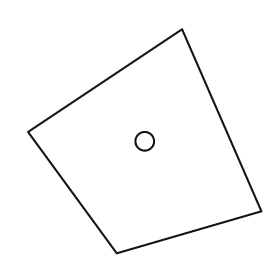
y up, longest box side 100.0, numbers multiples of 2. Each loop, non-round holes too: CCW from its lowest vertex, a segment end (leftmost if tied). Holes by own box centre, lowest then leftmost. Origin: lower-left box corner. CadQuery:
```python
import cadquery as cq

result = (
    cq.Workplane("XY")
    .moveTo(38.0, 0.0)
    .lineTo(100.0, 18.0)
    .lineTo(66.0, 96.0)
    .lineTo(0.0, 52.0)
    .close()
    .moveTo(50.0, 48.0)
    .circle(4.0)
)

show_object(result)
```